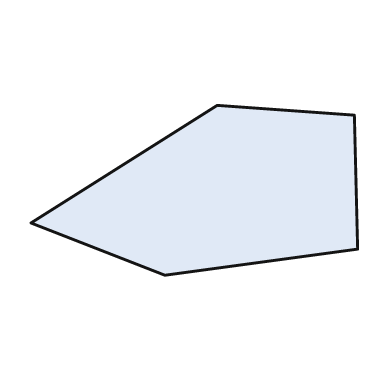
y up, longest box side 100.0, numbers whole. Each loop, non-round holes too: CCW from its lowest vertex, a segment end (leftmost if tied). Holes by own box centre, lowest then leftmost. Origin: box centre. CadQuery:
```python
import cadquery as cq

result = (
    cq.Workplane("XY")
    .moveTo(-9.0, -26.0)
    .lineTo(50.0, -18.0)
    .lineTo(49.0, 23.0)
    .lineTo(7.0, 26.0)
    .lineTo(-50.0, -10.0)
    .close()
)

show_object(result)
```